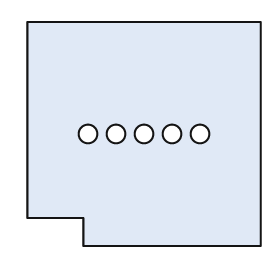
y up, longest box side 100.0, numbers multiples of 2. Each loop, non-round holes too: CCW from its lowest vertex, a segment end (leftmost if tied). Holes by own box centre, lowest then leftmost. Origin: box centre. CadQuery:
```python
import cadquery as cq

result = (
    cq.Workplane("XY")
    .moveTo(-26.0, -48.0)
    .lineTo(50.0, -48.0)
    .lineTo(50.0, 48.0)
    .lineTo(-50.0, 48.0)
    .lineTo(-50.0, -36.0)
    .lineTo(-26.0, -36.0)
    .close()
    .moveTo(-24.0, 0.0)
    .circle(4.0)
    .moveTo(-12.0, 0.0)
    .circle(4.0)
    .moveTo(0.0, 0.0)
    .circle(4.0)
    .moveTo(12.0, 0.0)
    .circle(4.0)
    .moveTo(24.0, 0.0)
    .circle(4.0)
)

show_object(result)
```